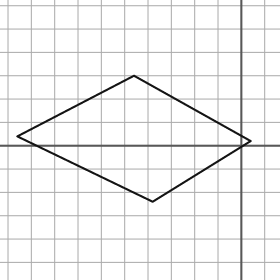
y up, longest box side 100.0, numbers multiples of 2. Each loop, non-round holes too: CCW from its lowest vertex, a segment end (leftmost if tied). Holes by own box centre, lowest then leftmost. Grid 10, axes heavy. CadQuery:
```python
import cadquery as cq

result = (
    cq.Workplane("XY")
    .moveTo(-38.0, -24.0)
    .lineTo(4.0, 2.0)
    .lineTo(-46.0, 30.0)
    .lineTo(-96.0, 4.0)
    .close()
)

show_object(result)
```